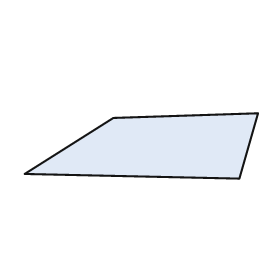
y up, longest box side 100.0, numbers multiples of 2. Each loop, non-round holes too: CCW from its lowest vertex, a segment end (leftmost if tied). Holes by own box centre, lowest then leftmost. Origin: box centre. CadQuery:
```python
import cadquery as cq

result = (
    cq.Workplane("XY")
    .moveTo(42.0, -14.0)
    .lineTo(50.0, 14.0)
    .lineTo(-12.0, 12.0)
    .lineTo(-50.0, -12.0)
    .close()
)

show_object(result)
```